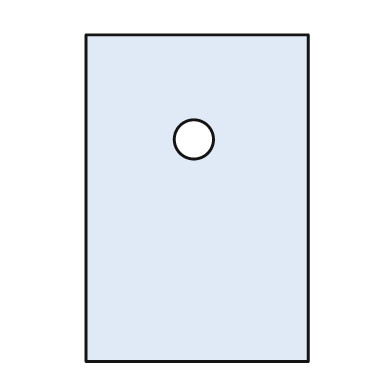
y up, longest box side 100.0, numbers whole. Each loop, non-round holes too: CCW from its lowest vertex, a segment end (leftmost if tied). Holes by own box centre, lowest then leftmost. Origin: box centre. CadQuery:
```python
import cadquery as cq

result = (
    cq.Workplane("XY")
    .moveTo(-34.0, -50.0)
    .lineTo(34.0, -50.0)
    .lineTo(34.0, 50.0)
    .lineTo(-34.0, 50.0)
    .close()
    .moveTo(-1.0, 18.0)
    .circle(6.0)
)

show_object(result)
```